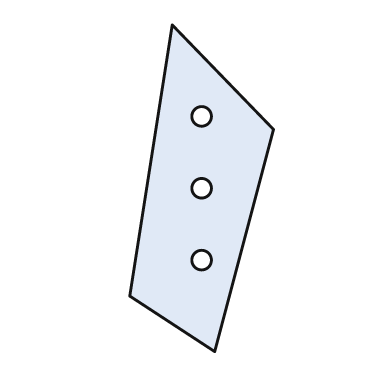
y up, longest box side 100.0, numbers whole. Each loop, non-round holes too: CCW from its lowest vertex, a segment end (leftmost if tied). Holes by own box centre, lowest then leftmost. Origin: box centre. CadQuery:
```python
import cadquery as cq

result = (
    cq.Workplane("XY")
    .moveTo(4.0, -50.0)
    .lineTo(22.0, 18.0)
    .lineTo(-9.0, 50.0)
    .lineTo(-22.0, -33.0)
    .close()
    .moveTo(0.0, -22.0)
    .circle(3.0)
    .moveTo(0.0, 0.0)
    .circle(3.0)
    .moveTo(0.0, 22.0)
    .circle(3.0)
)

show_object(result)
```